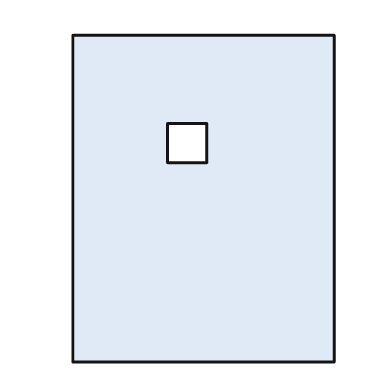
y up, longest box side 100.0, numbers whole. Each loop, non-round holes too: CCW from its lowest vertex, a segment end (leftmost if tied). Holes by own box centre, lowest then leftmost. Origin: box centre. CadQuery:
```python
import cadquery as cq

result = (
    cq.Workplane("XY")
    .moveTo(-40.0, -50.0)
    .lineTo(40.0, -50.0)
    .lineTo(40.0, 50.0)
    .lineTo(-40.0, 50.0)
    .close()
    .moveTo(-11.0, 11.0)
    .lineTo(1.0, 11.0)
    .lineTo(1.0, 23.0)
    .lineTo(-11.0, 23.0)
    .close()
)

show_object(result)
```